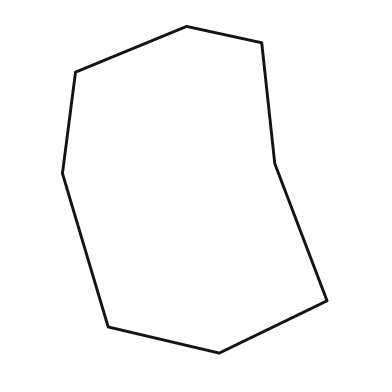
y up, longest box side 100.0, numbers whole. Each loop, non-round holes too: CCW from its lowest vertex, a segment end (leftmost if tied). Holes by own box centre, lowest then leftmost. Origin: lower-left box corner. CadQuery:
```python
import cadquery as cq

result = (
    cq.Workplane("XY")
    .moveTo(48.0, 0.0)
    .lineTo(81.0, 16.0)
    .lineTo(65.0, 58.0)
    .lineTo(61.0, 95.0)
    .lineTo(38.0, 100.0)
    .lineTo(4.0, 86.0)
    .lineTo(0.0, 55.0)
    .lineTo(14.0, 8.0)
    .close()
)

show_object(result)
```